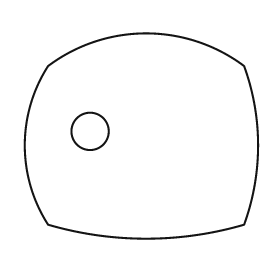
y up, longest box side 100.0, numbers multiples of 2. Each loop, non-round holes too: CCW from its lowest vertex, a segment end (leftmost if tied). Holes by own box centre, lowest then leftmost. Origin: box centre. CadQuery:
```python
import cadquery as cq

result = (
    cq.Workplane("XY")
    .moveTo(-40.0, -38.0)
    .threePointArc((2.0, -44.0), (44.0, -38.0))
    .threePointArc((50.0, -4.0), (44.0, 30.0))
    .threePointArc((2.0, 44.0), (-40.0, 30.0))
    .threePointArc((-50.0, -4.0), (-40.0, -38.0))
    .close()
    .moveTo(-22.0, 2.0)
    .circle(8.0)
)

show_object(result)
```